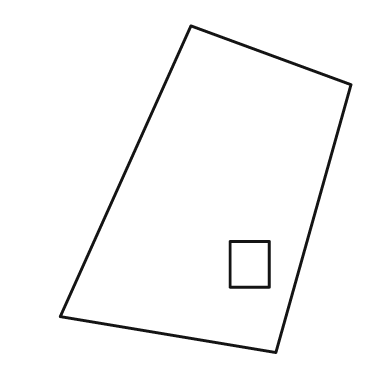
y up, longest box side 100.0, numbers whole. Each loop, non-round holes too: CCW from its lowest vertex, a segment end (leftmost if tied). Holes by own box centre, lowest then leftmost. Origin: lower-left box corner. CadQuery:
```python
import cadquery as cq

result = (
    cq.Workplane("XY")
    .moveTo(66.0, 0.0)
    .lineTo(89.0, 82.0)
    .lineTo(40.0, 100.0)
    .lineTo(0.0, 11.0)
    .close()
    .moveTo(52.0, 20.0)
    .lineTo(64.0, 20.0)
    .lineTo(64.0, 34.0)
    .lineTo(52.0, 34.0)
    .close()
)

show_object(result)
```